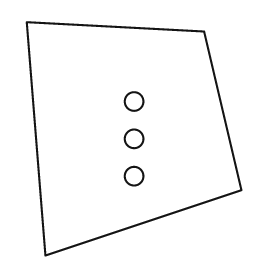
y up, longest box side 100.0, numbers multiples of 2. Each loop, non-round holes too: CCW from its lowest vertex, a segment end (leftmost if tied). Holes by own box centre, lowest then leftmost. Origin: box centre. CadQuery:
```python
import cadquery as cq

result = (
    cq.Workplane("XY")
    .moveTo(-38.0, -50.0)
    .lineTo(46.0, -22.0)
    .lineTo(30.0, 46.0)
    .lineTo(-46.0, 50.0)
    .close()
    .moveTo(0.0, -16.0)
    .circle(4.0)
    .moveTo(0.0, 0.0)
    .circle(4.0)
    .moveTo(0.0, 16.0)
    .circle(4.0)
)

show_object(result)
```